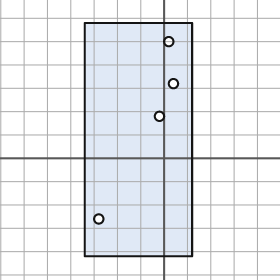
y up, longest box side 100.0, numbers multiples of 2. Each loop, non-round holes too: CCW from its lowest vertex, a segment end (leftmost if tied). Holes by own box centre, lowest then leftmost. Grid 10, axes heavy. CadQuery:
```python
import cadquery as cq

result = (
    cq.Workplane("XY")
    .moveTo(-34.0, -42.0)
    .lineTo(12.0, -42.0)
    .lineTo(12.0, 58.0)
    .lineTo(-34.0, 58.0)
    .close()
    .moveTo(-28.0, -26.0)
    .circle(2.0)
    .moveTo(-2.0, 18.0)
    .circle(2.0)
    .moveTo(4.0, 32.0)
    .circle(2.0)
    .moveTo(2.0, 50.0)
    .circle(2.0)
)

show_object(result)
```